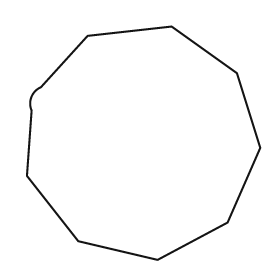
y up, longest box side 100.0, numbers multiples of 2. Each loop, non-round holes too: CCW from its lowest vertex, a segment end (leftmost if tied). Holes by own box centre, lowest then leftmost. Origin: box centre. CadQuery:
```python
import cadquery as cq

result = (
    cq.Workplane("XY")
    .moveTo(6.0, -50.0)
    .lineTo(36.0, -34.0)
    .lineTo(50.0, -2.0)
    .lineTo(40.0, 30.0)
    .lineTo(12.0, 50.0)
    .lineTo(-24.0, 46.0)
    .lineTo(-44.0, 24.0)
    .threePointArc((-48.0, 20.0), (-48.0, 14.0))
    .lineTo(-50.0, -14.0)
    .lineTo(-28.0, -42.0)
    .close()
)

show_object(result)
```